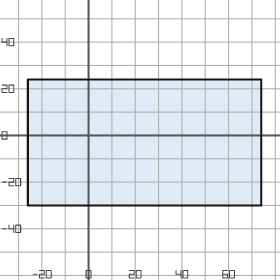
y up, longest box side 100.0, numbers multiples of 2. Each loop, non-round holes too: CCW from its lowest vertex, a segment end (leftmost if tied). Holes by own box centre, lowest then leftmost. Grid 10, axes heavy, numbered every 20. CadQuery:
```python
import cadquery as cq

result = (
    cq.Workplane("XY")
    .moveTo(-26.0, -30.0)
    .lineTo(74.0, -30.0)
    .lineTo(74.0, 24.0)
    .lineTo(-26.0, 24.0)
    .close()
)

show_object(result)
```